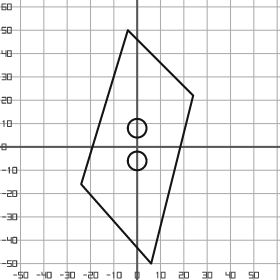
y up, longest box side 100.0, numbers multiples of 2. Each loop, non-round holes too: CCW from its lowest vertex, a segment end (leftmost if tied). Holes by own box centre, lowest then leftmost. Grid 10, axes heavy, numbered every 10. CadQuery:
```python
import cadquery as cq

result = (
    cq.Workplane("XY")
    .moveTo(6.0, -50.0)
    .lineTo(24.0, 22.0)
    .lineTo(-4.0, 50.0)
    .lineTo(-24.0, -16.0)
    .close()
    .moveTo(0.0, -6.0)
    .circle(4.0)
    .moveTo(0.0, 8.0)
    .circle(4.0)
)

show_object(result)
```